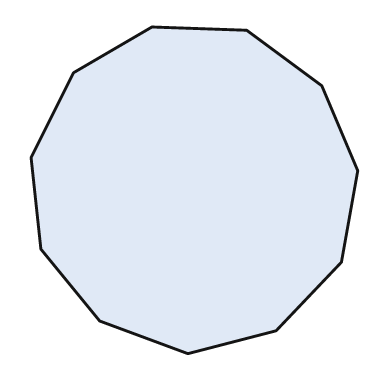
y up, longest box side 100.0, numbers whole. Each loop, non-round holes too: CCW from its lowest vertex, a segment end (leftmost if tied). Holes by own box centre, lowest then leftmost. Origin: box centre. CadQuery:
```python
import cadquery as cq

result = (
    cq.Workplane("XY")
    .moveTo(-2.0, -50.0)
    .lineTo(25.0, -43.0)
    .lineTo(45.0, -22.0)
    .lineTo(50.0, 6.0)
    .lineTo(39.0, 32.0)
    .lineTo(16.0, 49.0)
    .lineTo(-13.0, 50.0)
    .lineTo(-37.0, 36.0)
    .lineTo(-50.0, 10.0)
    .lineTo(-47.0, -18.0)
    .lineTo(-29.0, -40.0)
    .close()
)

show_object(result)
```